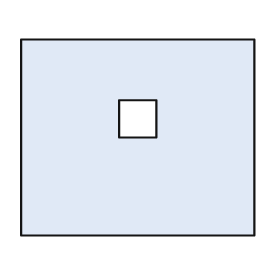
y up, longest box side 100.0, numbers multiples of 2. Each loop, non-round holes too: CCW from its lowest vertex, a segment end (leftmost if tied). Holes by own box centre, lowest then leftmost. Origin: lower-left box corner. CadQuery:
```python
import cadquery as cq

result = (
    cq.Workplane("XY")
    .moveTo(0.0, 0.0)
    .lineTo(100.0, 0.0)
    .lineTo(100.0, 84.0)
    .lineTo(0.0, 84.0)
    .close()
    .moveTo(42.0, 42.0)
    .lineTo(58.0, 42.0)
    .lineTo(58.0, 58.0)
    .lineTo(42.0, 58.0)
    .close()
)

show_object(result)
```